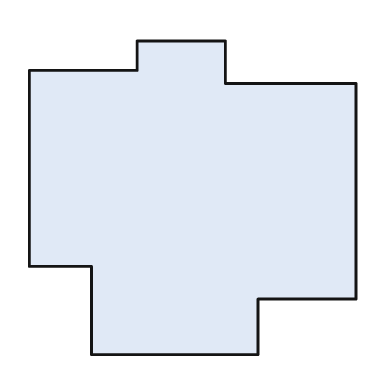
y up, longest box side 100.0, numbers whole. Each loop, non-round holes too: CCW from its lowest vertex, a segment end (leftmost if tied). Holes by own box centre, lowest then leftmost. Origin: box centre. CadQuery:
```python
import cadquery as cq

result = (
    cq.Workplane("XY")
    .moveTo(-31.0, -48.0)
    .lineTo(20.0, -48.0)
    .lineTo(20.0, -31.0)
    .lineTo(50.0, -31.0)
    .lineTo(50.0, 35.0)
    .lineTo(10.0, 35.0)
    .lineTo(10.0, 48.0)
    .lineTo(-17.0, 48.0)
    .lineTo(-17.0, 39.0)
    .lineTo(-50.0, 39.0)
    .lineTo(-50.0, -21.0)
    .lineTo(-31.0, -21.0)
    .close()
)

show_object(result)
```